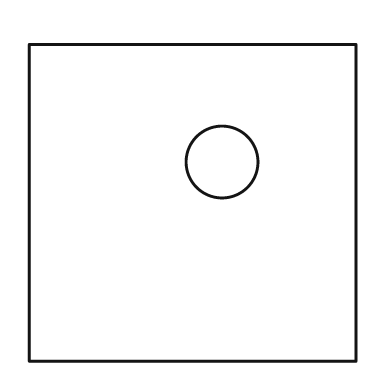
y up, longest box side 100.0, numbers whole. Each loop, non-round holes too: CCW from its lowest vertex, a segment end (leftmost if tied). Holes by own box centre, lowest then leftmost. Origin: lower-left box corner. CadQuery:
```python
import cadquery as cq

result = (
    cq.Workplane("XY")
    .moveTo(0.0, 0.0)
    .lineTo(100.0, 0.0)
    .lineTo(100.0, 97.0)
    .lineTo(0.0, 97.0)
    .close()
    .moveTo(59.0, 61.0)
    .circle(11.0)
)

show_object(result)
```